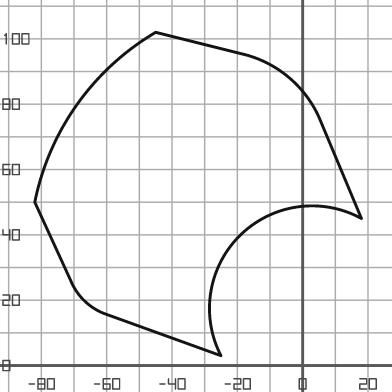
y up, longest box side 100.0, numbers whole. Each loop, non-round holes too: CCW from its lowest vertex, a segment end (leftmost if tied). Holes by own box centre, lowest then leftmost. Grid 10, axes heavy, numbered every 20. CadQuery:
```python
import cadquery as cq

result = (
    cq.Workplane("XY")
    .moveTo(-25.0, 3.0)
    .threePointArc((-19.0, 40.0), (18.0, 45.0))
    .lineTo(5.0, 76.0)
    .threePointArc((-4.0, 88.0), (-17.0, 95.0))
    .lineTo(-45.0, 102.0)
    .threePointArc((-69.0, 80.0), (-82.0, 50.0))
    .lineTo(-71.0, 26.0)
    .threePointArc((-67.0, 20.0), (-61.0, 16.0))
    .close()
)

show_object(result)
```